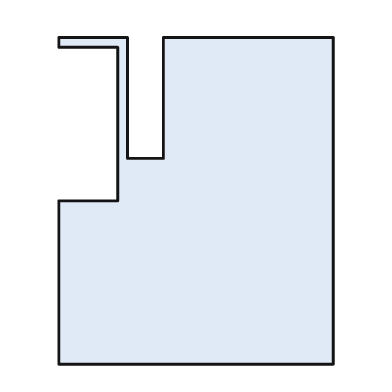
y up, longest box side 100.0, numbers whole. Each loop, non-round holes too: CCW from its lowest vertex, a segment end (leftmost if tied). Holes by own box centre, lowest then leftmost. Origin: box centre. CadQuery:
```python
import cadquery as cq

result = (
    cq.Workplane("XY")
    .moveTo(-42.0, -50.0)
    .lineTo(42.0, -50.0)
    .lineTo(42.0, 50.0)
    .lineTo(-10.0, 50.0)
    .lineTo(-10.0, 13.0)
    .lineTo(-21.0, 13.0)
    .lineTo(-21.0, 50.0)
    .lineTo(-42.0, 50.0)
    .lineTo(-42.0, 47.0)
    .lineTo(-24.0, 47.0)
    .lineTo(-24.0, 0.0)
    .lineTo(-42.0, 0.0)
    .close()
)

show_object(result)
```